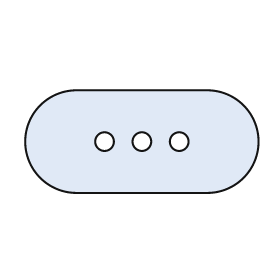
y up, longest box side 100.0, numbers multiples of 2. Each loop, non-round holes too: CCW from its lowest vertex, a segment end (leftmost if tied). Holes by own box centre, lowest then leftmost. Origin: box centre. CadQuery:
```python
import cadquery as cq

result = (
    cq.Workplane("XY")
    .moveTo(-28.0, -22.0)
    .lineTo(28.0, -22.0)
    .threePointArc((50.0, 0.0), (28.0, 22.0))
    .lineTo(-28.0, 22.0)
    .threePointArc((-50.0, 0.0), (-28.0, -22.0))
    .close()
    .moveTo(-16.0, 0.0)
    .circle(4.0)
    .moveTo(0.0, 0.0)
    .circle(4.0)
    .moveTo(16.0, 0.0)
    .circle(4.0)
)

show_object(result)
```